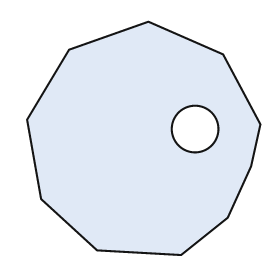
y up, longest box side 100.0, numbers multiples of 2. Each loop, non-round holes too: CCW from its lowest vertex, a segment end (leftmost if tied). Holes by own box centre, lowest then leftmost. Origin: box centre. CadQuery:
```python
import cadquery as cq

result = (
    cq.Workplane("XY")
    .moveTo(16.0, -50.0)
    .lineTo(36.0, -34.0)
    .lineTo(46.0, -12.0)
    .lineTo(50.0, 6.0)
    .lineTo(34.0, 36.0)
    .lineTo(2.0, 50.0)
    .lineTo(-32.0, 38.0)
    .lineTo(-50.0, 8.0)
    .lineTo(-44.0, -26.0)
    .lineTo(-20.0, -48.0)
    .close()
    .moveTo(22.0, 4.0)
    .circle(10.0)
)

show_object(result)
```